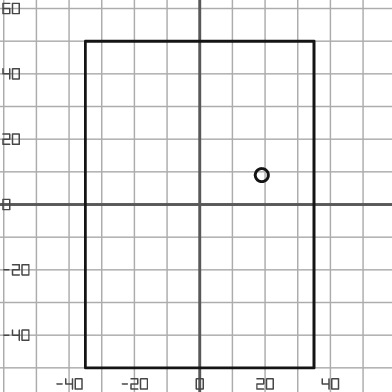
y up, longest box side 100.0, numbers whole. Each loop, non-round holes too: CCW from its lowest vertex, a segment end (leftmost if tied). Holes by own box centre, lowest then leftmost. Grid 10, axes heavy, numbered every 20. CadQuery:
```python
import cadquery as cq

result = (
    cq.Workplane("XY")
    .moveTo(-35.0, -50.0)
    .lineTo(35.0, -50.0)
    .lineTo(35.0, 50.0)
    .lineTo(-35.0, 50.0)
    .close()
    .moveTo(19.0, 9.0)
    .circle(2.0)
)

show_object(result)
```